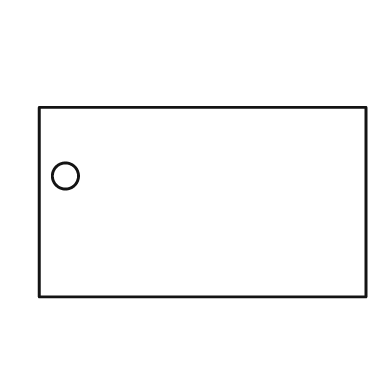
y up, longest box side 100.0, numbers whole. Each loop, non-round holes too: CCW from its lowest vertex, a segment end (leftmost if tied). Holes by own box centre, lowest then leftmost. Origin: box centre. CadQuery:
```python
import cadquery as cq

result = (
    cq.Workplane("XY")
    .moveTo(-50.0, -29.0)
    .lineTo(50.0, -29.0)
    .lineTo(50.0, 29.0)
    .lineTo(-50.0, 29.0)
    .close()
    .moveTo(-42.0, 8.0)
    .circle(4.0)
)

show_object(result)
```